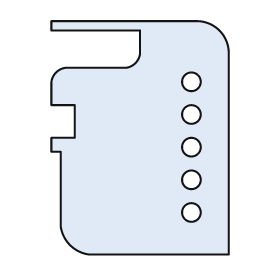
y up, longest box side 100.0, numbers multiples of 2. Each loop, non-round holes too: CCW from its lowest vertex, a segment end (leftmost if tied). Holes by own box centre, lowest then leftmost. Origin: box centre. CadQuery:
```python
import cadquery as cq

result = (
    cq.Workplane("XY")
    .moveTo(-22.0, -50.0)
    .lineTo(38.0, -50.0)
    .lineTo(38.0, 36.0)
    .threePointArc((34.0, 46.0), (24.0, 50.0))
    .lineTo(-38.0, 50.0)
    .lineTo(-38.0, 46.0)
    .lineTo(0.0, 46.0)
    .lineTo(0.0, 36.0)
    .threePointArc((-2.0, 32.0), (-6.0, 30.0))
    .lineTo(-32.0, 30.0)
    .threePointArc((-36.0, 28.0), (-38.0, 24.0))
    .lineTo(-38.0, 14.0)
    .lineTo(-28.0, 14.0)
    .lineTo(-28.0, 0.0)
    .lineTo(-38.0, 0.0)
    .lineTo(-38.0, -6.0)
    .lineTo(-34.0, -6.0)
    .lineTo(-34.0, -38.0)
    .threePointArc((-30.0, -46.0), (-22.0, -50.0))
    .close()
    .moveTo(22.0, -32.0)
    .circle(4.0)
    .moveTo(22.0, -18.0)
    .circle(4.0)
    .moveTo(22.0, -4.0)
    .circle(4.0)
    .moveTo(22.0, 10.0)
    .circle(4.0)
    .moveTo(22.0, 24.0)
    .circle(4.0)
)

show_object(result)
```